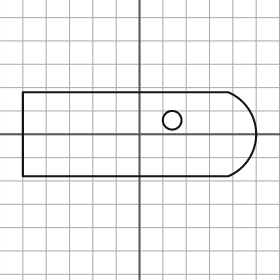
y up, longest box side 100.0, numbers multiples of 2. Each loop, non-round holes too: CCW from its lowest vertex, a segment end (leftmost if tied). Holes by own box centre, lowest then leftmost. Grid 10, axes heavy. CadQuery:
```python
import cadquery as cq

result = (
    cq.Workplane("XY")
    .moveTo(-50.0, -18.0)
    .lineTo(38.0, -18.0)
    .threePointArc((50.0, 0.0), (38.0, 18.0))
    .lineTo(-50.0, 18.0)
    .close()
    .moveTo(14.0, 6.0)
    .circle(4.0)
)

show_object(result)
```